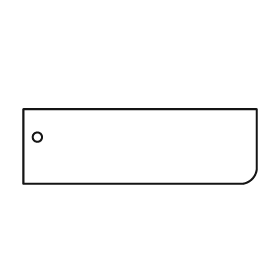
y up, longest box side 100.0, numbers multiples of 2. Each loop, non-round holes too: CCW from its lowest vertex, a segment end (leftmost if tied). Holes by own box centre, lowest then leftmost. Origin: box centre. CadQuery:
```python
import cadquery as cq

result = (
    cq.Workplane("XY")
    .moveTo(-50.0, -16.0)
    .lineTo(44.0, -16.0)
    .threePointArc((48.0, -14.0), (50.0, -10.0))
    .lineTo(50.0, 16.0)
    .lineTo(-50.0, 16.0)
    .close()
    .moveTo(-44.0, 4.0)
    .circle(2.0)
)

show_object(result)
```